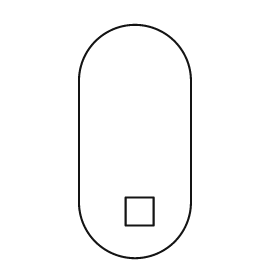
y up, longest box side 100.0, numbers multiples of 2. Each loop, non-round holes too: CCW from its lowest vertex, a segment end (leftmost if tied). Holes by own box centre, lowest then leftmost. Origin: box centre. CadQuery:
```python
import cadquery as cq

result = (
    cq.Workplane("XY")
    .moveTo(-24.0, -26.0)
    .threePointArc((0.0, -50.0), (24.0, -26.0))
    .lineTo(24.0, 26.0)
    .threePointArc((0.0, 50.0), (-24.0, 26.0))
    .close()
    .moveTo(-4.0, -36.0)
    .lineTo(8.0, -36.0)
    .lineTo(8.0, -24.0)
    .lineTo(-4.0, -24.0)
    .close()
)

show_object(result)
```